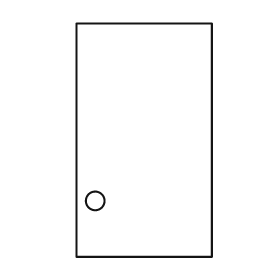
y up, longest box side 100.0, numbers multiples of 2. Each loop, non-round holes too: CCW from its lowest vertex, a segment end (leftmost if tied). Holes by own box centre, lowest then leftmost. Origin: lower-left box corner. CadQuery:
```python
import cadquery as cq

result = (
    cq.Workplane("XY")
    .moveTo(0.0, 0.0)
    .lineTo(58.0, 0.0)
    .lineTo(58.0, 100.0)
    .lineTo(0.0, 100.0)
    .close()
    .moveTo(8.0, 24.0)
    .circle(4.0)
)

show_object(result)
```